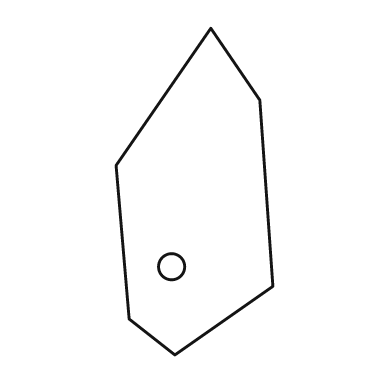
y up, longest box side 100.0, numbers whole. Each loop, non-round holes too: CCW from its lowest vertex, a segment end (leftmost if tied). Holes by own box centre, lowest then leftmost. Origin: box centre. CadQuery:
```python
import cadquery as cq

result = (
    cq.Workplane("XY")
    .moveTo(-6.0, -50.0)
    .lineTo(24.0, -29.0)
    .lineTo(20.0, 28.0)
    .lineTo(5.0, 50.0)
    .lineTo(-24.0, 8.0)
    .lineTo(-20.0, -39.0)
    .close()
    .moveTo(-7.0, -23.0)
    .circle(4.0)
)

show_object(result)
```